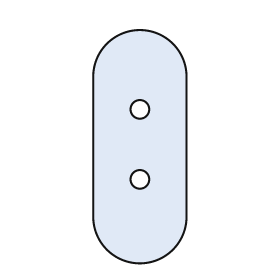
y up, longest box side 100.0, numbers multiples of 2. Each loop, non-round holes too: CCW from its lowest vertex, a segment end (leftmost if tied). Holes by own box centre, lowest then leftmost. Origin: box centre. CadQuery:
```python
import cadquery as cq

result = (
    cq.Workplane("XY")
    .moveTo(-20.0, -30.0)
    .threePointArc((0.0, -50.0), (20.0, -30.0))
    .lineTo(20.0, 30.0)
    .threePointArc((0.0, 50.0), (-20.0, 30.0))
    .close()
    .moveTo(0.0, -14.0)
    .circle(4.0)
    .moveTo(0.0, 16.0)
    .circle(4.0)
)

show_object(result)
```